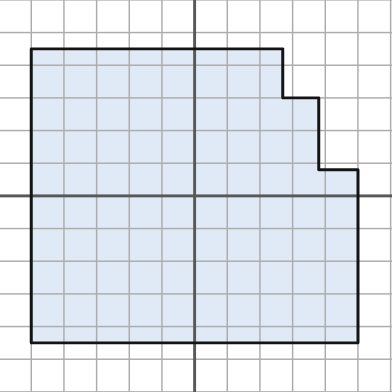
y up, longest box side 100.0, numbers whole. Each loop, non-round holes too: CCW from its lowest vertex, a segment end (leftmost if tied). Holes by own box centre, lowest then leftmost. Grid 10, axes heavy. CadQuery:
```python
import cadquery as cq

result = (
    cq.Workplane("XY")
    .moveTo(-50.0, -45.0)
    .lineTo(50.0, -45.0)
    .lineTo(50.0, 8.0)
    .lineTo(38.0, 8.0)
    .lineTo(38.0, 30.0)
    .lineTo(27.0, 30.0)
    .lineTo(27.0, 45.0)
    .lineTo(-50.0, 45.0)
    .close()
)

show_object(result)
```